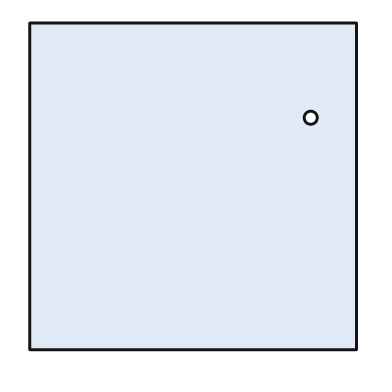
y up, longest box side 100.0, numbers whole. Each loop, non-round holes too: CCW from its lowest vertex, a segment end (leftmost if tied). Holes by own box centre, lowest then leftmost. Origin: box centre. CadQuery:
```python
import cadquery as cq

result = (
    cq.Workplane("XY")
    .moveTo(-50.0, -50.0)
    .lineTo(50.0, -50.0)
    .lineTo(50.0, 50.0)
    .lineTo(-50.0, 50.0)
    .close()
    .moveTo(36.0, 21.0)
    .circle(2.0)
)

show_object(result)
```